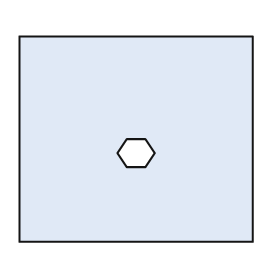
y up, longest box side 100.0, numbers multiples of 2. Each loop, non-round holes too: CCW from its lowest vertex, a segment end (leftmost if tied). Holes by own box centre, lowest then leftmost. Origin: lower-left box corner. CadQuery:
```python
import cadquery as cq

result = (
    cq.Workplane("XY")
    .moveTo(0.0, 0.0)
    .lineTo(100.0, 0.0)
    .lineTo(100.0, 88.0)
    .lineTo(0.0, 88.0)
    .close()
    .moveTo(46.0, 32.0)
    .lineTo(54.0, 32.0)
    .lineTo(58.0, 38.0)
    .lineTo(54.0, 44.0)
    .lineTo(46.0, 44.0)
    .lineTo(42.0, 38.0)
    .close()
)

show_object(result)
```